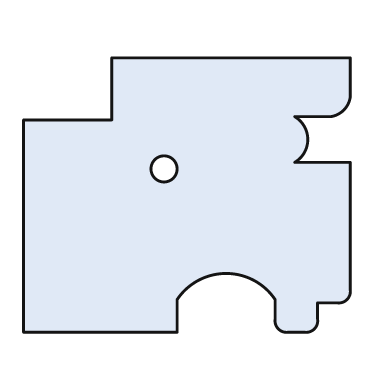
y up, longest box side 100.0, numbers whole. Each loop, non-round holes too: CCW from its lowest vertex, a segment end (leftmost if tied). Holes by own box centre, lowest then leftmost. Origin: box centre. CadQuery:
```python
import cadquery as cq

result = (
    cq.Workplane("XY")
    .moveTo(-50.0, -42.0)
    .lineTo(-3.0, -42.0)
    .lineTo(-3.0, -32.0)
    .threePointArc((12.0, -24.0), (27.0, -32.0))
    .lineTo(27.0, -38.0)
    .threePointArc((28.0, -41.0), (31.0, -42.0))
    .lineTo(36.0, -42.0)
    .threePointArc((39.0, -41.0), (40.0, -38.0))
    .lineTo(40.0, -33.0)
    .lineTo(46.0, -33.0)
    .threePointArc((49.0, -32.0), (50.0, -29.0))
    .lineTo(50.0, 10.0)
    .lineTo(33.0, 10.0)
    .threePointArc((37.0, 17.0), (33.0, 24.0))
    .lineTo(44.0, 24.0)
    .threePointArc((48.0, 26.0), (50.0, 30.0))
    .lineTo(50.0, 42.0)
    .lineTo(-23.0, 42.0)
    .lineTo(-23.0, 23.0)
    .lineTo(-50.0, 23.0)
    .close()
    .moveTo(-7.0, 8.0)
    .circle(4.0)
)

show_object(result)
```